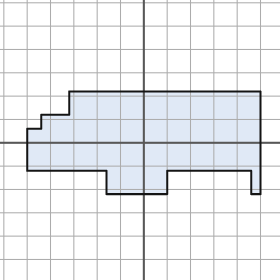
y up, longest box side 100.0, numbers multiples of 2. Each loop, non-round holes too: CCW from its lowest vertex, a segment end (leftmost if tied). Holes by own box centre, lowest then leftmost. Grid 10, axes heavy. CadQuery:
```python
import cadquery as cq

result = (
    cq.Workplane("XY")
    .moveTo(-16.0, -22.0)
    .lineTo(10.0, -22.0)
    .lineTo(10.0, -12.0)
    .lineTo(46.0, -12.0)
    .lineTo(46.0, -22.0)
    .lineTo(50.0, -22.0)
    .lineTo(50.0, 22.0)
    .lineTo(-32.0, 22.0)
    .lineTo(-32.0, 12.0)
    .lineTo(-44.0, 12.0)
    .lineTo(-44.0, 6.0)
    .lineTo(-50.0, 6.0)
    .lineTo(-50.0, -12.0)
    .lineTo(-16.0, -12.0)
    .close()
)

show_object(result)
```